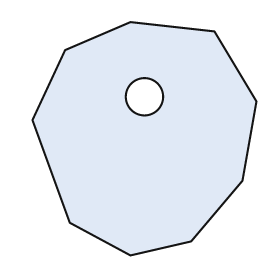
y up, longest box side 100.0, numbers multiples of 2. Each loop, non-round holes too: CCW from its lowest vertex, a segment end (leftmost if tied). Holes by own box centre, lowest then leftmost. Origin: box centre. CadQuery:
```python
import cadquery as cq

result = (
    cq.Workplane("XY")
    .moveTo(-6.0, -50.0)
    .lineTo(20.0, -44.0)
    .lineTo(42.0, -18.0)
    .lineTo(48.0, 16.0)
    .lineTo(30.0, 46.0)
    .lineTo(-6.0, 50.0)
    .lineTo(-34.0, 38.0)
    .lineTo(-48.0, 8.0)
    .lineTo(-32.0, -36.0)
    .close()
    .moveTo(0.0, 18.0)
    .circle(8.0)
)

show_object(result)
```